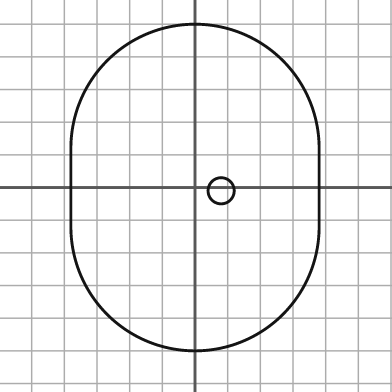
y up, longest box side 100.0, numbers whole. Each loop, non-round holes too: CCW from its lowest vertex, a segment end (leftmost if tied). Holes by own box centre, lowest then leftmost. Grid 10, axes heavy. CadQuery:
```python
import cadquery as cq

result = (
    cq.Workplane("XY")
    .moveTo(-38.0, -12.0)
    .threePointArc((0.0, -50.0), (38.0, -12.0))
    .lineTo(38.0, 12.0)
    .threePointArc((0.0, 50.0), (-38.0, 12.0))
    .close()
    .moveTo(8.0, -1.0)
    .circle(4.0)
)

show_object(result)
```